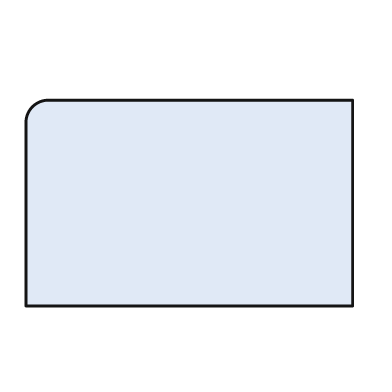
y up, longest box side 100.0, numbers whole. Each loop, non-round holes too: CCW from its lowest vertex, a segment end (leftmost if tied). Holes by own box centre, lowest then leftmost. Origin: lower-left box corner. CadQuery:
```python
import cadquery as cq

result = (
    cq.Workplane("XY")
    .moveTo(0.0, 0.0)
    .lineTo(100.0, 0.0)
    .lineTo(100.0, 63.0)
    .lineTo(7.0, 63.0)
    .threePointArc((2.0, 61.0), (0.0, 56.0))
    .close()
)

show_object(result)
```